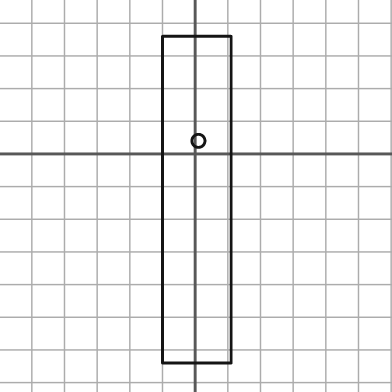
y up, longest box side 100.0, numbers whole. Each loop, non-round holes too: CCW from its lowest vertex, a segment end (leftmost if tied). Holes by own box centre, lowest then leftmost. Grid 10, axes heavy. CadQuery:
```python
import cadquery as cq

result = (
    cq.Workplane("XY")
    .moveTo(-10.0, -64.0)
    .lineTo(11.0, -64.0)
    .lineTo(11.0, 36.0)
    .lineTo(-10.0, 36.0)
    .close()
    .moveTo(1.0, 4.0)
    .circle(2.0)
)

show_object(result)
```